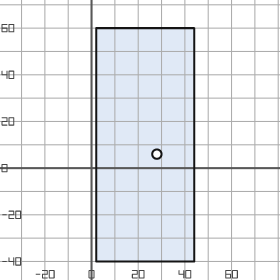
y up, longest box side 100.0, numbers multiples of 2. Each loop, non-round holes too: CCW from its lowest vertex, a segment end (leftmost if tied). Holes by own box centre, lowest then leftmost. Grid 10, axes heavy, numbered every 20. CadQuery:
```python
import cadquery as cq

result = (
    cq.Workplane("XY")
    .moveTo(2.0, -40.0)
    .lineTo(44.0, -40.0)
    .lineTo(44.0, 60.0)
    .lineTo(2.0, 60.0)
    .close()
    .moveTo(28.0, 6.0)
    .circle(2.0)
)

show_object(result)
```